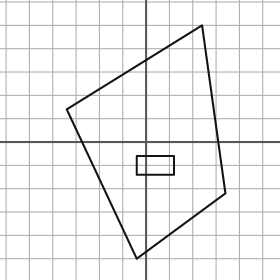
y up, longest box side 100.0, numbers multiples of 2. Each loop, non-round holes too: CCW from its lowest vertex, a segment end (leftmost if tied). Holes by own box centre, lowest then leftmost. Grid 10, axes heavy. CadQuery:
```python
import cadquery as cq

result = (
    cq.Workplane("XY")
    .moveTo(-4.0, -50.0)
    .lineTo(34.0, -22.0)
    .lineTo(24.0, 50.0)
    .lineTo(-34.0, 14.0)
    .close()
    .moveTo(-4.0, -14.0)
    .lineTo(12.0, -14.0)
    .lineTo(12.0, -6.0)
    .lineTo(-4.0, -6.0)
    .close()
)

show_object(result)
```